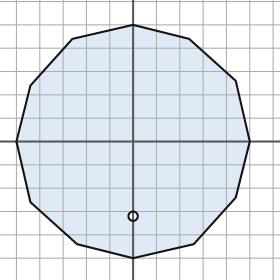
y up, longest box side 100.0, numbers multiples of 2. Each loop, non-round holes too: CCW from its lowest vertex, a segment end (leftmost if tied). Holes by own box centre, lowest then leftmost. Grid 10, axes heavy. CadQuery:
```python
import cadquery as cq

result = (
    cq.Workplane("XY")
    .moveTo(0.0, -50.0)
    .lineTo(26.0, -44.0)
    .lineTo(44.0, -24.0)
    .lineTo(50.0, 0.0)
    .lineTo(44.0, 26.0)
    .lineTo(24.0, 44.0)
    .lineTo(0.0, 50.0)
    .lineTo(-26.0, 44.0)
    .lineTo(-44.0, 24.0)
    .lineTo(-50.0, 0.0)
    .lineTo(-44.0, -26.0)
    .lineTo(-24.0, -44.0)
    .close()
    .moveTo(0.0, -32.0)
    .circle(2.0)
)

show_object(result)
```